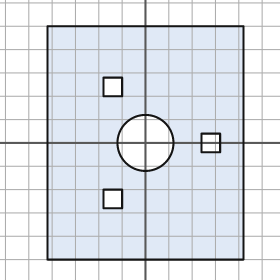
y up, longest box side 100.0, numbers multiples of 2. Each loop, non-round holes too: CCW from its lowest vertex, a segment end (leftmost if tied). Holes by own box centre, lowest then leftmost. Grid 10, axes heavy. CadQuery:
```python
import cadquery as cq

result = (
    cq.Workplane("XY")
    .moveTo(-42.0, -50.0)
    .lineTo(42.0, -50.0)
    .lineTo(42.0, 50.0)
    .lineTo(-42.0, 50.0)
    .close()
    .moveTo(-18.0, -28.0)
    .lineTo(-10.0, -28.0)
    .lineTo(-10.0, -20.0)
    .lineTo(-18.0, -20.0)
    .close()
    .moveTo(0.0, 0.0)
    .circle(12.0)
    .moveTo(24.0, -4.0)
    .lineTo(32.0, -4.0)
    .lineTo(32.0, 4.0)
    .lineTo(24.0, 4.0)
    .close()
    .moveTo(-18.0, 20.0)
    .lineTo(-10.0, 20.0)
    .lineTo(-10.0, 28.0)
    .lineTo(-18.0, 28.0)
    .close()
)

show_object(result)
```